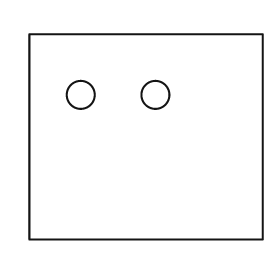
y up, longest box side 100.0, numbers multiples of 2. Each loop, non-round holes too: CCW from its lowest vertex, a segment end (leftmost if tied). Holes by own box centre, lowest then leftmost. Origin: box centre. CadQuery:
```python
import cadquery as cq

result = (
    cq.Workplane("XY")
    .moveTo(-50.0, -44.0)
    .lineTo(50.0, -44.0)
    .lineTo(50.0, 44.0)
    .lineTo(-50.0, 44.0)
    .close()
    .moveTo(-28.0, 18.0)
    .circle(6.0)
    .moveTo(4.0, 18.0)
    .circle(6.0)
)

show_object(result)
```